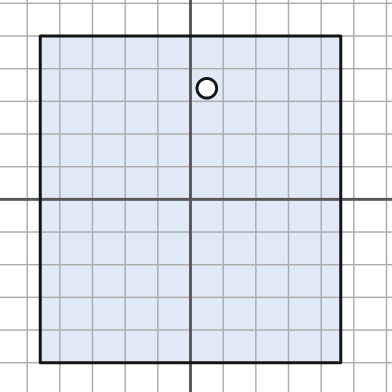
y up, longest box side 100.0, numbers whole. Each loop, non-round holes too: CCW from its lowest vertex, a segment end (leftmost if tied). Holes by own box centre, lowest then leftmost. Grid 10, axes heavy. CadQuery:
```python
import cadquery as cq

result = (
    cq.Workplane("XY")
    .moveTo(-46.0, -50.0)
    .lineTo(46.0, -50.0)
    .lineTo(46.0, 50.0)
    .lineTo(-46.0, 50.0)
    .close()
    .moveTo(5.0, 34.0)
    .circle(3.0)
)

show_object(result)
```